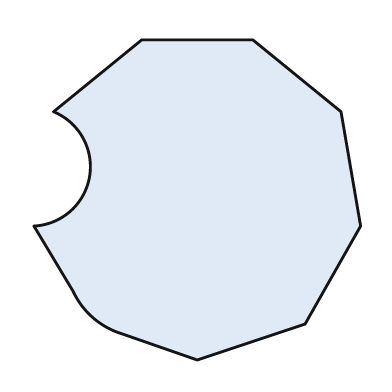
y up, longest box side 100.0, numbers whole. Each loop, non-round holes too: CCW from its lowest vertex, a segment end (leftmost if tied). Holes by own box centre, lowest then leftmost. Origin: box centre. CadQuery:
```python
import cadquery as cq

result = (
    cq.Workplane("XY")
    .moveTo(0.0, -49.0)
    .lineTo(33.0, -38.0)
    .lineTo(50.0, -8.0)
    .lineTo(44.0, 27.0)
    .lineTo(17.0, 49.0)
    .lineTo(-17.0, 49.0)
    .lineTo(-44.0, 27.0)
    .threePointArc((-33.0, 7.0), (-50.0, -8.0))
    .lineTo(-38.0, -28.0)
    .threePointArc((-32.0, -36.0), (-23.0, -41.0))
    .close()
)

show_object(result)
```